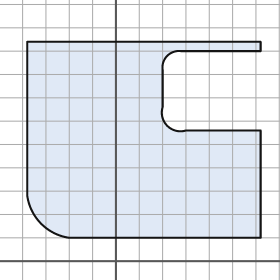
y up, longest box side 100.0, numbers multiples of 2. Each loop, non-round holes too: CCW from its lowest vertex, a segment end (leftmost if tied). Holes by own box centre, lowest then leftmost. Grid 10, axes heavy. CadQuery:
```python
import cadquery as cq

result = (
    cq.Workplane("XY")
    .moveTo(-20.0, 10.0)
    .lineTo(62.0, 10.0)
    .lineTo(62.0, 56.0)
    .lineTo(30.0, 56.0)
    .threePointArc((22.0, 58.0), (20.0, 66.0))
    .lineTo(20.0, 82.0)
    .threePointArc((22.0, 88.0), (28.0, 90.0))
    .lineTo(62.0, 90.0)
    .lineTo(62.0, 94.0)
    .lineTo(-38.0, 94.0)
    .lineTo(-38.0, 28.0)
    .threePointArc((-32.0, 16.0), (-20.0, 10.0))
    .close()
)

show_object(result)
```